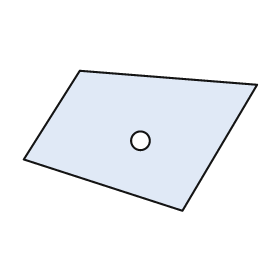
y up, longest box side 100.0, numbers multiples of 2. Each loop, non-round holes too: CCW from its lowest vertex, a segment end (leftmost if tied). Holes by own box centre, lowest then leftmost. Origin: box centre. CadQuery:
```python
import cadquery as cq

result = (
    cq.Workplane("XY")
    .moveTo(18.0, -30.0)
    .lineTo(50.0, 24.0)
    .lineTo(-26.0, 30.0)
    .lineTo(-50.0, -8.0)
    .close()
    .moveTo(0.0, 0.0)
    .circle(4.0)
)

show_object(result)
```